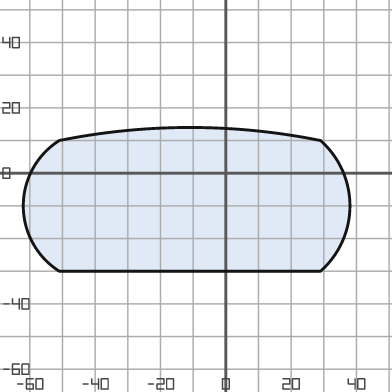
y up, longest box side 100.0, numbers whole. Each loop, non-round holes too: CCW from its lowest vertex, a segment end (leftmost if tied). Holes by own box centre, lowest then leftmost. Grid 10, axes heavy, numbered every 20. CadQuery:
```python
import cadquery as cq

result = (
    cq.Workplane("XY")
    .moveTo(-51.0, -30.0)
    .lineTo(29.0, -30.0)
    .threePointArc((38.0, -10.0), (29.0, 10.0))
    .threePointArc((-11.0, 14.0), (-51.0, 10.0))
    .threePointArc((-62.0, -10.0), (-51.0, -30.0))
    .close()
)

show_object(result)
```